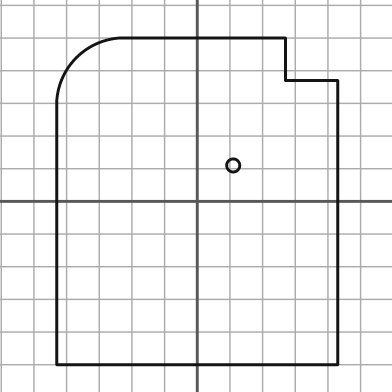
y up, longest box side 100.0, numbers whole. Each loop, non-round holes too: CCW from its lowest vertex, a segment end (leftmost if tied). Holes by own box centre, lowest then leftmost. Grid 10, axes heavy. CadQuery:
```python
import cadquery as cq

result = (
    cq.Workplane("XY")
    .moveTo(-43.0, -50.0)
    .lineTo(43.0, -50.0)
    .lineTo(43.0, 37.0)
    .lineTo(27.0, 37.0)
    .lineTo(27.0, 50.0)
    .lineTo(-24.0, 50.0)
    .threePointArc((-37.0, 44.0), (-43.0, 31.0))
    .close()
    .moveTo(11.0, 11.0)
    .circle(2.0)
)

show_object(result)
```